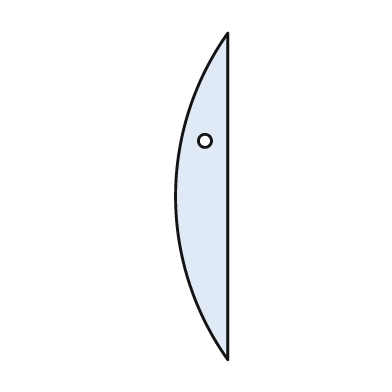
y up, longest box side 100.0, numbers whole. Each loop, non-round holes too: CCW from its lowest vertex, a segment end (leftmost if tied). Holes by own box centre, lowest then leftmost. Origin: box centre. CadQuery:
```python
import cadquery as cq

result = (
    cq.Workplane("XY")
    .moveTo(8.0, -50.0)
    .lineTo(8.0, 50.0)
    .threePointArc((-8.0, 0.0), (8.0, -50.0))
    .close()
    .moveTo(1.0, 17.0)
    .circle(2.0)
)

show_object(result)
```